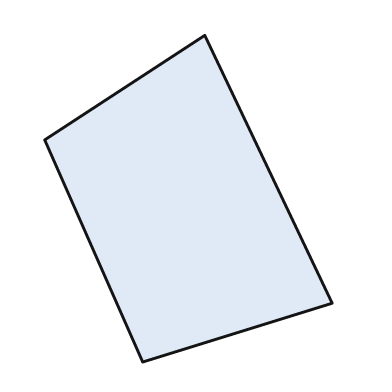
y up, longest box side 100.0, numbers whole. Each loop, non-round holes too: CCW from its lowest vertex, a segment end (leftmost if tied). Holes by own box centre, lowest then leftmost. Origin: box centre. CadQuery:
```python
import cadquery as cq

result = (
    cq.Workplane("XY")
    .moveTo(-14.0, -50.0)
    .lineTo(44.0, -32.0)
    .lineTo(5.0, 50.0)
    .lineTo(-44.0, 18.0)
    .close()
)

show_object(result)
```